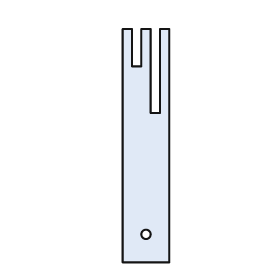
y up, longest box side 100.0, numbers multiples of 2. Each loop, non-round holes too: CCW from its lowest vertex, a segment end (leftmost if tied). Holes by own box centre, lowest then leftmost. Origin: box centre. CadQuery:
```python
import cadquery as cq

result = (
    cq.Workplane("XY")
    .moveTo(-10.0, -50.0)
    .lineTo(10.0, -50.0)
    .lineTo(10.0, 50.0)
    .lineTo(6.0, 50.0)
    .lineTo(6.0, 14.0)
    .lineTo(2.0, 14.0)
    .lineTo(2.0, 50.0)
    .lineTo(-2.0, 50.0)
    .lineTo(-2.0, 34.0)
    .lineTo(-6.0, 34.0)
    .lineTo(-6.0, 50.0)
    .lineTo(-10.0, 50.0)
    .close()
    .moveTo(0.0, -38.0)
    .circle(2.0)
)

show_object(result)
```